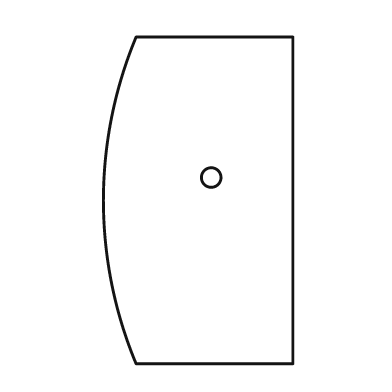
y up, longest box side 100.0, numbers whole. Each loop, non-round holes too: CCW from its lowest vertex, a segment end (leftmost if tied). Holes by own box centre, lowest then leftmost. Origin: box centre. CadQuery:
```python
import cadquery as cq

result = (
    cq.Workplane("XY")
    .moveTo(-19.0, -50.0)
    .lineTo(29.0, -50.0)
    .lineTo(29.0, 50.0)
    .lineTo(-19.0, 50.0)
    .threePointArc((-29.0, 0.0), (-19.0, -50.0))
    .close()
    .moveTo(4.0, 7.0)
    .circle(3.0)
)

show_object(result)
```